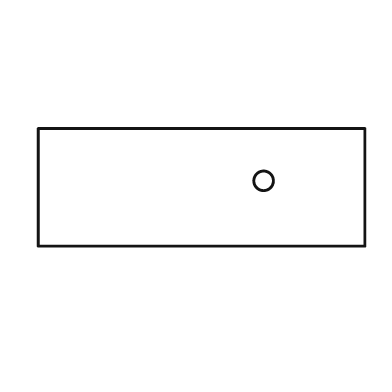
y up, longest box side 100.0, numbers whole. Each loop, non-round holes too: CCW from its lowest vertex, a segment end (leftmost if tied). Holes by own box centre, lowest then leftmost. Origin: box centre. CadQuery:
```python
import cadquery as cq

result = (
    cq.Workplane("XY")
    .moveTo(-50.0, -18.0)
    .lineTo(50.0, -18.0)
    .lineTo(50.0, 18.0)
    .lineTo(-50.0, 18.0)
    .close()
    .moveTo(19.0, 2.0)
    .circle(3.0)
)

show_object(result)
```